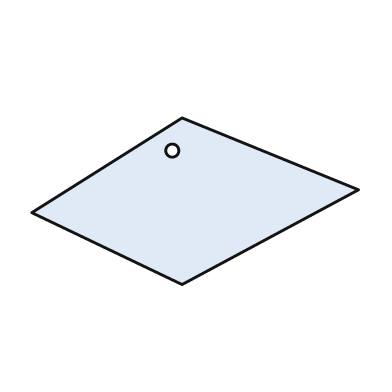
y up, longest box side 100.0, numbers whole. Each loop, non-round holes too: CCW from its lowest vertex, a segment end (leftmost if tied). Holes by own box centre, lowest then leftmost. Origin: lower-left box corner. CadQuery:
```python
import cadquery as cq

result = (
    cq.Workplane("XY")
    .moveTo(46.0, 0.0)
    .lineTo(100.0, 29.0)
    .lineTo(46.0, 51.0)
    .lineTo(0.0, 22.0)
    .close()
    .moveTo(43.0, 41.0)
    .circle(2.0)
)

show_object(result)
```